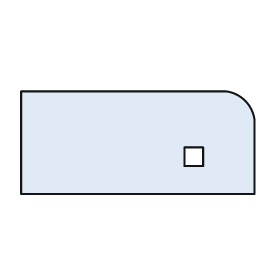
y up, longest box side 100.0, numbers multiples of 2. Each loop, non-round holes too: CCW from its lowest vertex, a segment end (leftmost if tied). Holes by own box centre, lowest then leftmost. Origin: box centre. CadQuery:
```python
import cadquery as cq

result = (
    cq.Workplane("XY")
    .moveTo(-50.0, -22.0)
    .lineTo(50.0, -22.0)
    .lineTo(50.0, 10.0)
    .threePointArc((46.0, 18.0), (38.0, 22.0))
    .lineTo(-50.0, 22.0)
    .close()
    .moveTo(20.0, -10.0)
    .lineTo(28.0, -10.0)
    .lineTo(28.0, -2.0)
    .lineTo(20.0, -2.0)
    .close()
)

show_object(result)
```